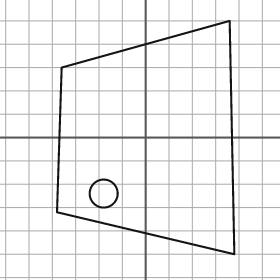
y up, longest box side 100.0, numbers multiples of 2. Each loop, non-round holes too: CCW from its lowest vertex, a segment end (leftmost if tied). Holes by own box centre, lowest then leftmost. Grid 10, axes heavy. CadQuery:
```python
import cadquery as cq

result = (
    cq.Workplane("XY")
    .moveTo(38.0, -50.0)
    .lineTo(36.0, 50.0)
    .lineTo(-36.0, 30.0)
    .lineTo(-38.0, -32.0)
    .close()
    .moveTo(-18.0, -24.0)
    .circle(6.0)
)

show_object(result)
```